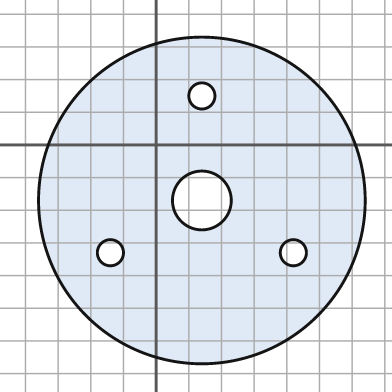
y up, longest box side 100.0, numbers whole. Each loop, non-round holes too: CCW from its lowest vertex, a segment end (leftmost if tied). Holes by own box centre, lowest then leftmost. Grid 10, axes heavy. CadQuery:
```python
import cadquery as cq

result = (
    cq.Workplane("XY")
    .moveTo(14.0, -17.0)
    .circle(50.0)
    .moveTo(-14.0, -33.0)
    .circle(4.0)
    .moveTo(42.0, -33.0)
    .circle(4.0)
    .moveTo(14.0, -17.0)
    .circle(9.0)
    .moveTo(14.0, 15.0)
    .circle(4.0)
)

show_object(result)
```